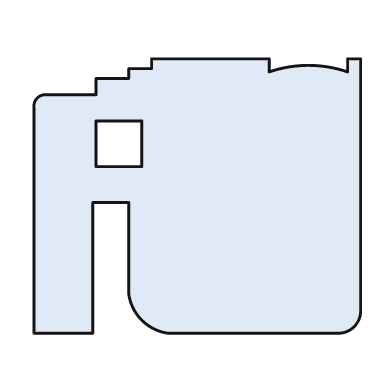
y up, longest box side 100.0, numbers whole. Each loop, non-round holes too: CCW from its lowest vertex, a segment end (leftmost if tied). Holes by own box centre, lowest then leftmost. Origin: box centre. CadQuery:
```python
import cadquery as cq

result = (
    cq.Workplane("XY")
    .moveTo(-50.0, -42.0)
    .lineTo(-32.0, -42.0)
    .lineTo(-32.0, -2.0)
    .lineTo(-21.0, -2.0)
    .lineTo(-21.0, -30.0)
    .threePointArc((-17.0, -38.0), (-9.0, -42.0))
    .lineTo(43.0, -42.0)
    .threePointArc((48.0, -40.0), (50.0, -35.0))
    .lineTo(50.0, 42.0)
    .lineTo(46.0, 42.0)
    .lineTo(46.0, 38.0)
    .threePointArc((34.0, 40.0), (22.0, 38.0))
    .lineTo(22.0, 42.0)
    .lineTo(-14.0, 42.0)
    .lineTo(-14.0, 39.0)
    .lineTo(-21.0, 39.0)
    .lineTo(-21.0, 36.0)
    .lineTo(-31.0, 36.0)
    .lineTo(-31.0, 31.0)
    .lineTo(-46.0, 31.0)
    .threePointArc((-49.0, 30.0), (-50.0, 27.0))
    .close()
    .moveTo(-31.0, 9.0)
    .lineTo(-17.0, 9.0)
    .lineTo(-17.0, 23.0)
    .lineTo(-31.0, 23.0)
    .close()
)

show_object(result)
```